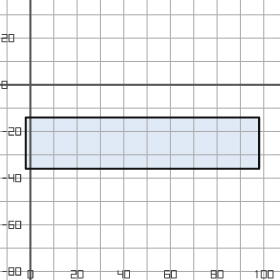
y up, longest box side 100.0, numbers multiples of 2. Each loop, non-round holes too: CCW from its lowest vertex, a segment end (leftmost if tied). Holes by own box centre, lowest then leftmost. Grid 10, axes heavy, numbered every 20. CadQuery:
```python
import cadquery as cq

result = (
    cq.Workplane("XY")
    .moveTo(-2.0, -36.0)
    .lineTo(98.0, -36.0)
    .lineTo(98.0, -14.0)
    .lineTo(-2.0, -14.0)
    .close()
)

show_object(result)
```